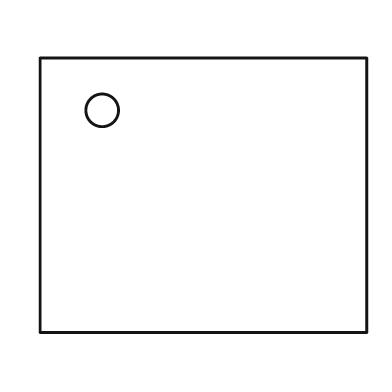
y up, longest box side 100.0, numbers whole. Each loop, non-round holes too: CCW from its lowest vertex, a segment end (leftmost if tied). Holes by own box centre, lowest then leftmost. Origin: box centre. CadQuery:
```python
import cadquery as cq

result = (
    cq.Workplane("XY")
    .moveTo(-50.0, -42.0)
    .lineTo(50.0, -42.0)
    .lineTo(50.0, 42.0)
    .lineTo(-50.0, 42.0)
    .close()
    .moveTo(-31.0, 26.0)
    .circle(5.0)
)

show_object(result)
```